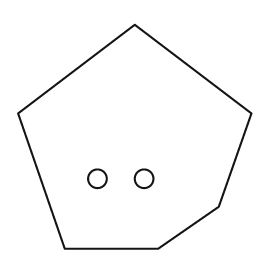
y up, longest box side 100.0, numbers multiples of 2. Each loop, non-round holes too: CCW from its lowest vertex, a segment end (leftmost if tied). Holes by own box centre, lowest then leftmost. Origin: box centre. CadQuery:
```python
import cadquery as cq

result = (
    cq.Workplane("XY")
    .moveTo(-30.0, -48.0)
    .lineTo(10.0, -48.0)
    .lineTo(36.0, -30.0)
    .lineTo(50.0, 10.0)
    .lineTo(0.0, 48.0)
    .lineTo(-50.0, 10.0)
    .close()
    .moveTo(-16.0, -18.0)
    .circle(4.0)
    .moveTo(4.0, -18.0)
    .circle(4.0)
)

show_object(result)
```